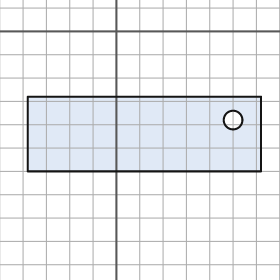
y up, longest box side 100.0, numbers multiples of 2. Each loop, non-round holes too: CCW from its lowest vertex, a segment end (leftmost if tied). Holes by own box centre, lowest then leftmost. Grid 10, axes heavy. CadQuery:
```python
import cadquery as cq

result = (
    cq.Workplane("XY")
    .moveTo(-38.0, -60.0)
    .lineTo(62.0, -60.0)
    .lineTo(62.0, -28.0)
    .lineTo(-38.0, -28.0)
    .close()
    .moveTo(50.0, -38.0)
    .circle(4.0)
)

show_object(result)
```